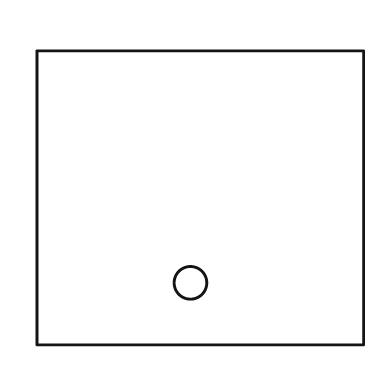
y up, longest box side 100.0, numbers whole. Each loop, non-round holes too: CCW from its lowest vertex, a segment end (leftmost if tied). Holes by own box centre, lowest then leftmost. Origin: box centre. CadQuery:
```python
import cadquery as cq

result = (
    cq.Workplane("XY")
    .moveTo(-50.0, -45.0)
    .lineTo(50.0, -45.0)
    .lineTo(50.0, 45.0)
    .lineTo(-50.0, 45.0)
    .close()
    .moveTo(-3.0, -26.0)
    .circle(5.0)
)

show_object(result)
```